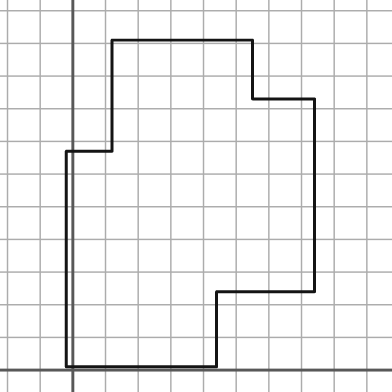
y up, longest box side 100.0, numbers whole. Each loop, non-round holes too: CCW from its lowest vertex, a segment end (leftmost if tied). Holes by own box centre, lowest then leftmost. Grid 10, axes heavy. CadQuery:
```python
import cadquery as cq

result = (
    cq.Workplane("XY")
    .moveTo(-2.0, 1.0)
    .lineTo(44.0, 1.0)
    .lineTo(44.0, 24.0)
    .lineTo(74.0, 24.0)
    .lineTo(74.0, 83.0)
    .lineTo(55.0, 83.0)
    .lineTo(55.0, 101.0)
    .lineTo(12.0, 101.0)
    .lineTo(12.0, 67.0)
    .lineTo(-2.0, 67.0)
    .close()
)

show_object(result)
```